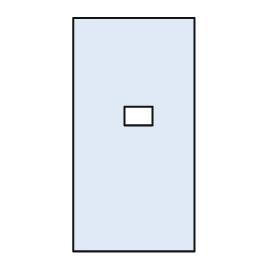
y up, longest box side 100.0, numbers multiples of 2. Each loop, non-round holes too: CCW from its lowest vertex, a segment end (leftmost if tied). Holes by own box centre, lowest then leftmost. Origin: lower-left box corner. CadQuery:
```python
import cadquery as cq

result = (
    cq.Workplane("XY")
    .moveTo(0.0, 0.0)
    .lineTo(52.0, 0.0)
    .lineTo(52.0, 100.0)
    .lineTo(0.0, 100.0)
    .close()
    .moveTo(22.0, 54.0)
    .lineTo(34.0, 54.0)
    .lineTo(34.0, 62.0)
    .lineTo(22.0, 62.0)
    .close()
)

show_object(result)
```